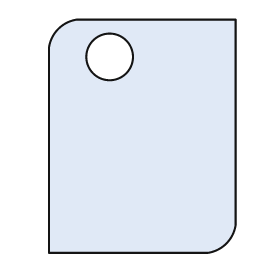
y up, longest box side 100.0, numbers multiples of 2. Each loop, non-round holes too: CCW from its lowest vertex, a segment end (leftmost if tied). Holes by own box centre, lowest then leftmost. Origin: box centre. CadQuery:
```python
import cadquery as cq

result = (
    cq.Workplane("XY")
    .moveTo(-40.0, -50.0)
    .lineTo(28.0, -50.0)
    .threePointArc((36.0, -46.0), (40.0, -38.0))
    .lineTo(40.0, 50.0)
    .lineTo(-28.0, 50.0)
    .threePointArc((-36.0, 46.0), (-40.0, 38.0))
    .close()
    .moveTo(-14.0, 34.0)
    .circle(10.0)
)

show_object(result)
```